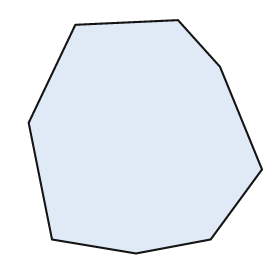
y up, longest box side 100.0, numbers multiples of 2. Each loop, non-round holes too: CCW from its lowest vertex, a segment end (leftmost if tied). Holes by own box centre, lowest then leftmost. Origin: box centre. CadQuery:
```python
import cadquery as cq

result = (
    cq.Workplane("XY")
    .moveTo(-4.0, -50.0)
    .lineTo(28.0, -44.0)
    .lineTo(50.0, -14.0)
    .lineTo(32.0, 30.0)
    .lineTo(14.0, 50.0)
    .lineTo(-30.0, 48.0)
    .lineTo(-50.0, 6.0)
    .lineTo(-40.0, -44.0)
    .close()
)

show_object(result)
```